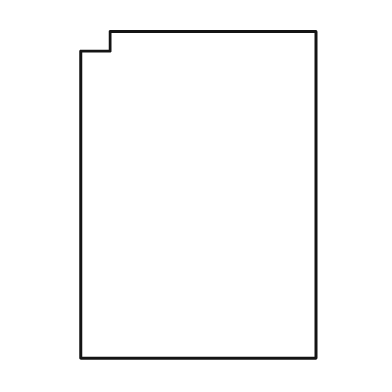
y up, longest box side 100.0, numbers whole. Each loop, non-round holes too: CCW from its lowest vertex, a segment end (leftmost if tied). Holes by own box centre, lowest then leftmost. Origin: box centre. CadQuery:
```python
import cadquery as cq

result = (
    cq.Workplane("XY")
    .moveTo(-36.0, -50.0)
    .lineTo(36.0, -50.0)
    .lineTo(36.0, 50.0)
    .lineTo(-27.0, 50.0)
    .lineTo(-27.0, 44.0)
    .lineTo(-36.0, 44.0)
    .close()
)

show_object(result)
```